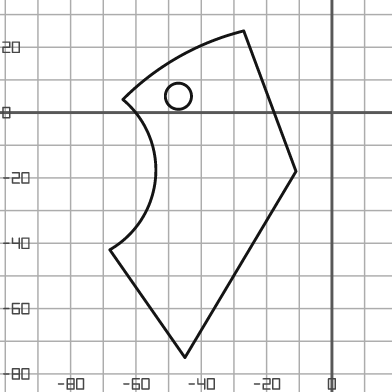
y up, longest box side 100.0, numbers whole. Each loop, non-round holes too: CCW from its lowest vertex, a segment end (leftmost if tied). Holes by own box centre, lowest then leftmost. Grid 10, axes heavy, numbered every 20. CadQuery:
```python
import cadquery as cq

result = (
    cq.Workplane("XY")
    .moveTo(-45.0, -75.0)
    .lineTo(-11.0, -18.0)
    .lineTo(-27.0, 25.0)
    .threePointArc((-47.0, 17.0), (-64.0, 4.0))
    .threePointArc((-54.0, -20.0), (-68.0, -42.0))
    .close()
    .moveTo(-47.0, 5.0)
    .circle(4.0)
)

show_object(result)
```